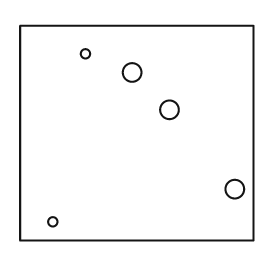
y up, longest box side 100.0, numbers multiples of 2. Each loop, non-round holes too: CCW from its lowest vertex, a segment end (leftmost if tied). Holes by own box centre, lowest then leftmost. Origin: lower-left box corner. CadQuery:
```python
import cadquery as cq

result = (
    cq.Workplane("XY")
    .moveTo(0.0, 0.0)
    .lineTo(100.0, 0.0)
    .lineTo(100.0, 92.0)
    .lineTo(0.0, 92.0)
    .close()
    .moveTo(14.0, 8.0)
    .circle(2.0)
    .moveTo(92.0, 22.0)
    .circle(4.0)
    .moveTo(64.0, 56.0)
    .circle(4.0)
    .moveTo(48.0, 72.0)
    .circle(4.0)
    .moveTo(28.0, 80.0)
    .circle(2.0)
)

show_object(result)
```